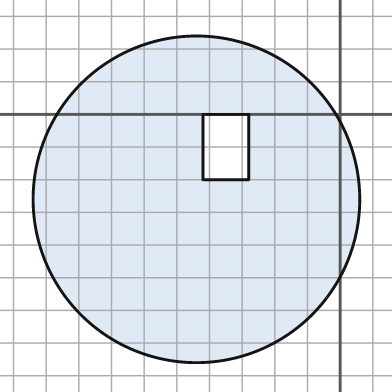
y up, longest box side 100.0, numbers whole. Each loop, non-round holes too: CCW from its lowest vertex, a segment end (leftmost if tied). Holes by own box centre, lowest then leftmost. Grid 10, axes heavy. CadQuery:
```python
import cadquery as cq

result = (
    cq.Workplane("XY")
    .moveTo(-44.0, -26.0)
    .circle(50.0)
    .moveTo(-42.0, -20.0)
    .lineTo(-28.0, -20.0)
    .lineTo(-28.0, 0.0)
    .lineTo(-42.0, 0.0)
    .close()
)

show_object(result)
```